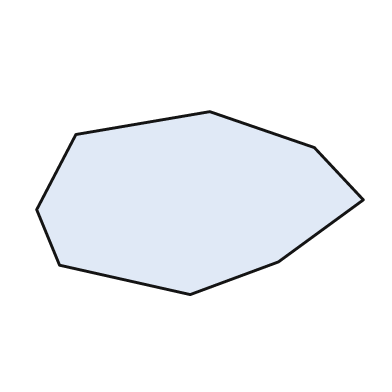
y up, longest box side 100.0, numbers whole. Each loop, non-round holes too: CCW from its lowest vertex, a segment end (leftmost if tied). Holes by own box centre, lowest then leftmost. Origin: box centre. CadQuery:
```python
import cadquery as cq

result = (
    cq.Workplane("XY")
    .moveTo(-3.0, -28.0)
    .lineTo(24.0, -18.0)
    .lineTo(50.0, 1.0)
    .lineTo(35.0, 17.0)
    .lineTo(3.0, 28.0)
    .lineTo(-38.0, 21.0)
    .lineTo(-50.0, -2.0)
    .lineTo(-43.0, -19.0)
    .close()
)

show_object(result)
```